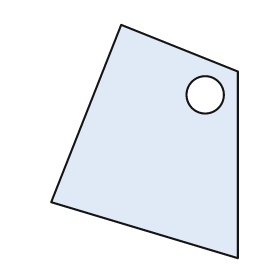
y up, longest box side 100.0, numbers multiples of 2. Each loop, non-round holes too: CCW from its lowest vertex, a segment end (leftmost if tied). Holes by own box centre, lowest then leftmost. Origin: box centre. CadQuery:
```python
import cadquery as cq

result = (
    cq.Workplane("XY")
    .moveTo(40.0, -50.0)
    .lineTo(40.0, 30.0)
    .lineTo(-10.0, 50.0)
    .lineTo(-40.0, -26.0)
    .close()
    .moveTo(26.0, 20.0)
    .circle(8.0)
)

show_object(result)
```